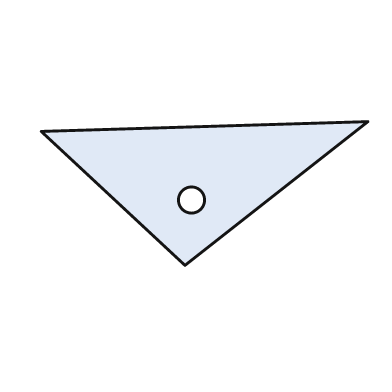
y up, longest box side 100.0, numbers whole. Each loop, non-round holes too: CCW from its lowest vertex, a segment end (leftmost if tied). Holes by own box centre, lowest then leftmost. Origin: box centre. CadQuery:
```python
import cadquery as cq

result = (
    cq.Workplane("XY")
    .moveTo(-6.0, -22.0)
    .lineTo(50.0, 22.0)
    .lineTo(-50.0, 19.0)
    .close()
    .moveTo(-4.0, -2.0)
    .circle(4.0)
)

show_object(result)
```